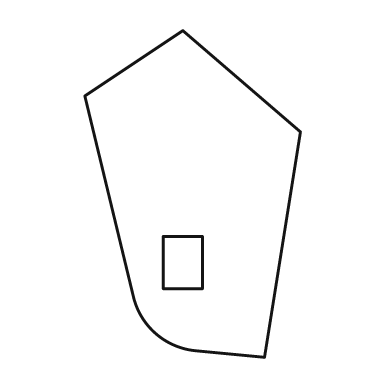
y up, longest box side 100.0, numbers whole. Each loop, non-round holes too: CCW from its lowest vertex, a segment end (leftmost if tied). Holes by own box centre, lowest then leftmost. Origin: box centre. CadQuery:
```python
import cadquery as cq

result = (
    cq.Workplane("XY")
    .moveTo(22.0, -50.0)
    .lineTo(33.0, 19.0)
    .lineTo(-3.0, 50.0)
    .lineTo(-33.0, 30.0)
    .lineTo(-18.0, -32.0)
    .threePointArc((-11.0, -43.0), (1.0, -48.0))
    .close()
    .moveTo(-9.0, -29.0)
    .lineTo(3.0, -29.0)
    .lineTo(3.0, -13.0)
    .lineTo(-9.0, -13.0)
    .close()
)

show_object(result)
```